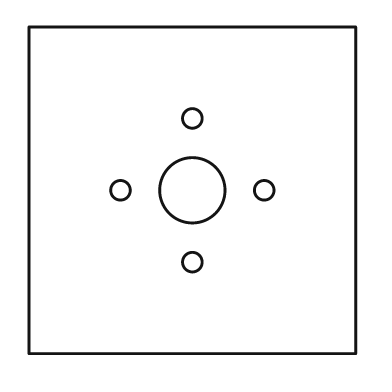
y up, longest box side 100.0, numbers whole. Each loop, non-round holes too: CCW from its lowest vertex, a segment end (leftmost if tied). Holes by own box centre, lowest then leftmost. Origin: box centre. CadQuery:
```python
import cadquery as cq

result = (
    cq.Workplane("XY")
    .moveTo(-50.0, -50.0)
    .lineTo(50.0, -50.0)
    .lineTo(50.0, 50.0)
    .lineTo(-50.0, 50.0)
    .close()
    .moveTo(0.0, -22.0)
    .circle(3.0)
    .moveTo(-22.0, 0.0)
    .circle(3.0)
    .moveTo(0.0, 0.0)
    .circle(10.0)
    .moveTo(22.0, 0.0)
    .circle(3.0)
    .moveTo(0.0, 22.0)
    .circle(3.0)
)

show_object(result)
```